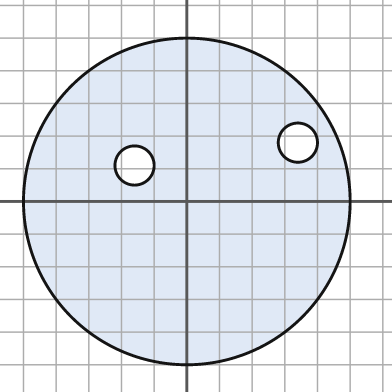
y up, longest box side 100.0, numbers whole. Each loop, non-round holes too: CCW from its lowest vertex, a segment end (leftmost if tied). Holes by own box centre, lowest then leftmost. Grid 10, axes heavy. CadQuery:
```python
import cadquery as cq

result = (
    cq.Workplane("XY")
    .moveTo(0.0, 0.0)
    .circle(50.0)
    .moveTo(-16.0, 11.0)
    .circle(6.0)
    .moveTo(34.0, 18.0)
    .circle(6.0)
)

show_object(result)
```